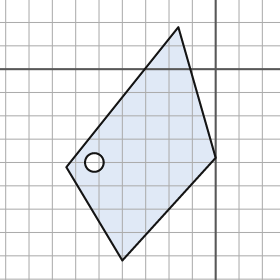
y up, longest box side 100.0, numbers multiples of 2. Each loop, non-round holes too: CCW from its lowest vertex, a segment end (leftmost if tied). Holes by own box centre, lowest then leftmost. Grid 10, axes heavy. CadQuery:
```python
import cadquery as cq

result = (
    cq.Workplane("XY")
    .moveTo(-40.0, -82.0)
    .lineTo(0.0, -38.0)
    .lineTo(-16.0, 18.0)
    .lineTo(-64.0, -42.0)
    .close()
    .moveTo(-52.0, -40.0)
    .circle(4.0)
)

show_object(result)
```